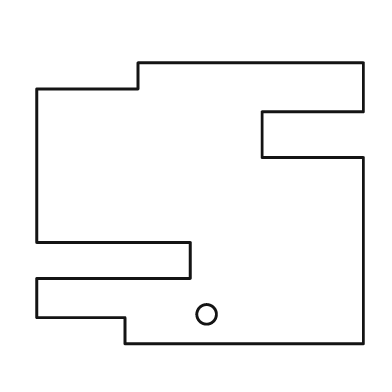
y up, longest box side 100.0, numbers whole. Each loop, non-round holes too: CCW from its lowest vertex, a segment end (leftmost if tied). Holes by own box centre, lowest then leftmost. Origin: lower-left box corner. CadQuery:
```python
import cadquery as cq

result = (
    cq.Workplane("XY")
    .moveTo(27.0, 0.0)
    .lineTo(100.0, 0.0)
    .lineTo(100.0, 57.0)
    .lineTo(69.0, 57.0)
    .lineTo(69.0, 71.0)
    .lineTo(100.0, 71.0)
    .lineTo(100.0, 86.0)
    .lineTo(31.0, 86.0)
    .lineTo(31.0, 78.0)
    .lineTo(0.0, 78.0)
    .lineTo(0.0, 31.0)
    .lineTo(47.0, 31.0)
    .lineTo(47.0, 20.0)
    .lineTo(0.0, 20.0)
    .lineTo(0.0, 8.0)
    .lineTo(27.0, 8.0)
    .close()
    .moveTo(52.0, 9.0)
    .circle(3.0)
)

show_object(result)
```